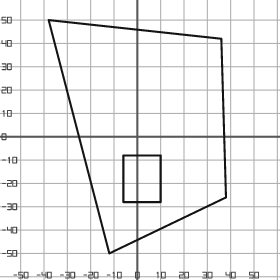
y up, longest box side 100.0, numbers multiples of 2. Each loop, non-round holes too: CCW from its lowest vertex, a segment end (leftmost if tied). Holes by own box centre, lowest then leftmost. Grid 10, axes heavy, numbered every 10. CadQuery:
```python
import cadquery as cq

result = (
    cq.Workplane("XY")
    .moveTo(-12.0, -50.0)
    .lineTo(38.0, -26.0)
    .lineTo(36.0, 42.0)
    .lineTo(-38.0, 50.0)
    .close()
    .moveTo(-6.0, -28.0)
    .lineTo(10.0, -28.0)
    .lineTo(10.0, -8.0)
    .lineTo(-6.0, -8.0)
    .close()
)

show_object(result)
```